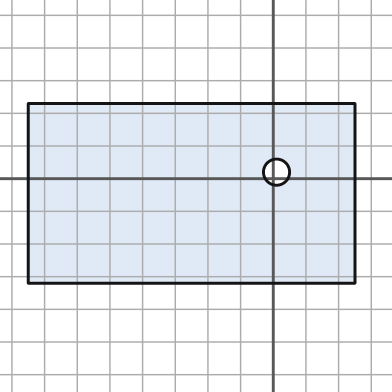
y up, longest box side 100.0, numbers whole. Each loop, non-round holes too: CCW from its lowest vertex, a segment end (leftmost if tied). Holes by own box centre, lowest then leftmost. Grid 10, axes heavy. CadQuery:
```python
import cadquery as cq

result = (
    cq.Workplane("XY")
    .moveTo(-75.0, -32.0)
    .lineTo(25.0, -32.0)
    .lineTo(25.0, 23.0)
    .lineTo(-75.0, 23.0)
    .close()
    .moveTo(1.0, 2.0)
    .circle(4.0)
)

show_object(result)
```